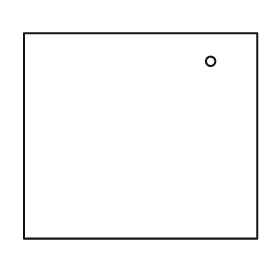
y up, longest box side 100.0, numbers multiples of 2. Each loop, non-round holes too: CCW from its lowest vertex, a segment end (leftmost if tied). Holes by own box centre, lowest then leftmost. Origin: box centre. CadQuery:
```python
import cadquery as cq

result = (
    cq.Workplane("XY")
    .moveTo(-50.0, -44.0)
    .lineTo(50.0, -44.0)
    .lineTo(50.0, 44.0)
    .lineTo(-50.0, 44.0)
    .close()
    .moveTo(30.0, 32.0)
    .circle(2.0)
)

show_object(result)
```